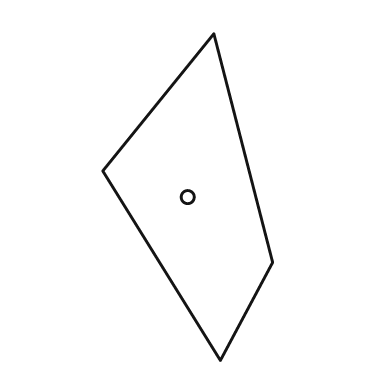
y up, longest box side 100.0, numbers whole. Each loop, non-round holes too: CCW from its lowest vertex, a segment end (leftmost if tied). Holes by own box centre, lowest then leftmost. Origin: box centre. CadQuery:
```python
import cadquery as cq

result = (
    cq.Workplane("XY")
    .moveTo(10.0, -50.0)
    .lineTo(26.0, -20.0)
    .lineTo(8.0, 50.0)
    .lineTo(-26.0, 8.0)
    .close()
    .moveTo(0.0, 0.0)
    .circle(2.0)
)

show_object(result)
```